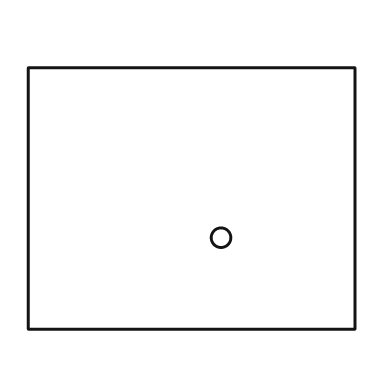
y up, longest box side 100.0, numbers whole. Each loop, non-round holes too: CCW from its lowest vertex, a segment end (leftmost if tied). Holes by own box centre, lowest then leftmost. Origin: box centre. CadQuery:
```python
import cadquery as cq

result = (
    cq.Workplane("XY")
    .moveTo(-50.0, -40.0)
    .lineTo(50.0, -40.0)
    .lineTo(50.0, 40.0)
    .lineTo(-50.0, 40.0)
    .close()
    .moveTo(9.0, -12.0)
    .circle(3.0)
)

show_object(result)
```